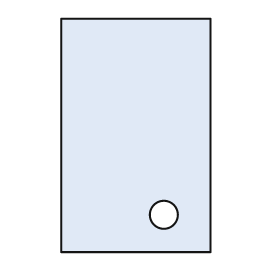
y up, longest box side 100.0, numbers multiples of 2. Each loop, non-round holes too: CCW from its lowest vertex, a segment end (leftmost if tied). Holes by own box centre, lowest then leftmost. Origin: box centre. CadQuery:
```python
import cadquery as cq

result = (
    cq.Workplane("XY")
    .moveTo(-32.0, -50.0)
    .lineTo(32.0, -50.0)
    .lineTo(32.0, 50.0)
    .lineTo(-32.0, 50.0)
    .close()
    .moveTo(12.0, -34.0)
    .circle(6.0)
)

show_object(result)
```